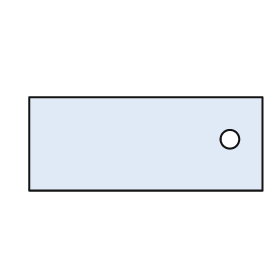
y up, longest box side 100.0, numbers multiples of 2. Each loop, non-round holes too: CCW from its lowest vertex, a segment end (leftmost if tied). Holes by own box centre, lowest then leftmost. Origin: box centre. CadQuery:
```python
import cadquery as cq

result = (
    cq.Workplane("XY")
    .moveTo(-50.0, -20.0)
    .lineTo(50.0, -20.0)
    .lineTo(50.0, 20.0)
    .lineTo(-50.0, 20.0)
    .close()
    .moveTo(36.0, 2.0)
    .circle(4.0)
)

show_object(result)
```